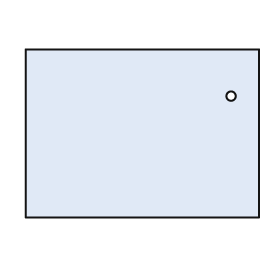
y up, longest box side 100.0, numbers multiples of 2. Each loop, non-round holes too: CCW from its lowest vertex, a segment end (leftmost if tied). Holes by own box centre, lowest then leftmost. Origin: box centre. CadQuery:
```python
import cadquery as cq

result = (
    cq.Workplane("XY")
    .moveTo(-50.0, -36.0)
    .lineTo(50.0, -36.0)
    .lineTo(50.0, 36.0)
    .lineTo(-50.0, 36.0)
    .close()
    .moveTo(38.0, 16.0)
    .circle(2.0)
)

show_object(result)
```